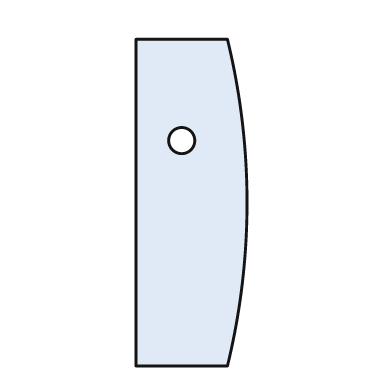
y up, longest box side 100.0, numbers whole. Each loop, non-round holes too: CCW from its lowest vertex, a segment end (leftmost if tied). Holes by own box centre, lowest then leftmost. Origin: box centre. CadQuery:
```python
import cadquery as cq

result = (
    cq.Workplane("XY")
    .moveTo(-17.0, -50.0)
    .lineTo(11.0, -50.0)
    .threePointArc((17.0, 0.0), (11.0, 50.0))
    .lineTo(-17.0, 50.0)
    .close()
    .moveTo(-3.0, 19.0)
    .circle(4.0)
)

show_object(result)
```